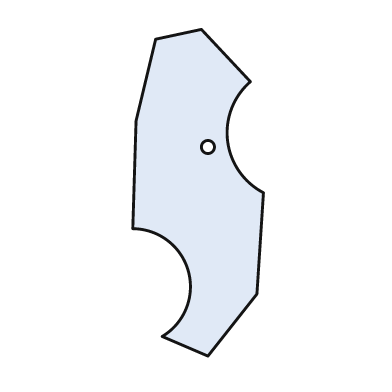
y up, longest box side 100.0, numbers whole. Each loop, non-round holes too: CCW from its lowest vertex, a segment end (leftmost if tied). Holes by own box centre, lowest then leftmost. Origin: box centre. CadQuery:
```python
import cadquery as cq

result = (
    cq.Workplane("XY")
    .moveTo(3.0, -50.0)
    .lineTo(18.0, -31.0)
    .lineTo(20.0, 0.0)
    .threePointArc((9.0, 16.0), (16.0, 34.0))
    .lineTo(1.0, 50.0)
    .lineTo(-13.0, 47.0)
    .lineTo(-19.0, 22.0)
    .lineTo(-20.0, -11.0)
    .threePointArc((-3.0, -24.0), (-11.0, -44.0))
    .close()
    .moveTo(3.0, 14.0)
    .circle(2.0)
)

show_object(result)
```